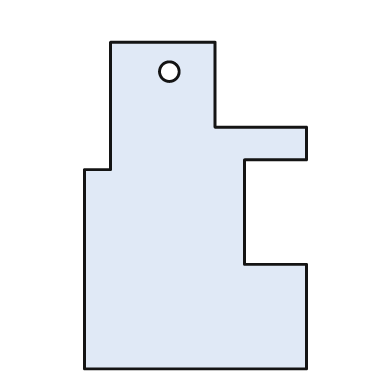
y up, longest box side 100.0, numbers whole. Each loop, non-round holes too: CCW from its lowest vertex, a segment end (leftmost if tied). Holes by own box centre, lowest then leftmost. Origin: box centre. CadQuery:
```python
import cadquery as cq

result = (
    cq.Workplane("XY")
    .moveTo(-34.0, -50.0)
    .lineTo(34.0, -50.0)
    .lineTo(34.0, -18.0)
    .lineTo(15.0, -18.0)
    .lineTo(15.0, 14.0)
    .lineTo(34.0, 14.0)
    .lineTo(34.0, 24.0)
    .lineTo(6.0, 24.0)
    .lineTo(6.0, 50.0)
    .lineTo(-26.0, 50.0)
    .lineTo(-26.0, 11.0)
    .lineTo(-34.0, 11.0)
    .close()
    .moveTo(-8.0, 41.0)
    .circle(3.0)
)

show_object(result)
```